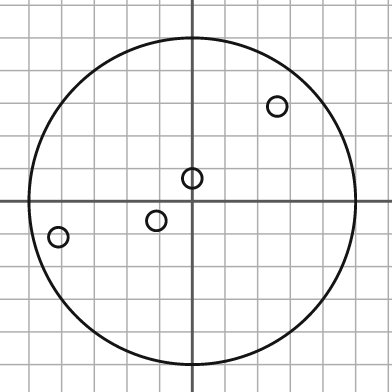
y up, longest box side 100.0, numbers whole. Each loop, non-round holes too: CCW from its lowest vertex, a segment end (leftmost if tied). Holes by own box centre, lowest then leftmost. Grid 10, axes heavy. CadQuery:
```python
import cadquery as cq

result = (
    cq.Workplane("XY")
    .moveTo(0.0, 0.0)
    .circle(50.0)
    .moveTo(-41.0, -11.0)
    .circle(3.0)
    .moveTo(-11.0, -6.0)
    .circle(3.0)
    .moveTo(0.0, 7.0)
    .circle(3.0)
    .moveTo(26.0, 29.0)
    .circle(3.0)
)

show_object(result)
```